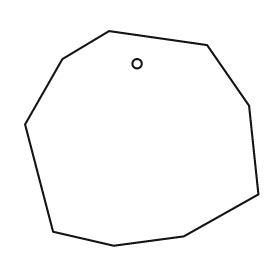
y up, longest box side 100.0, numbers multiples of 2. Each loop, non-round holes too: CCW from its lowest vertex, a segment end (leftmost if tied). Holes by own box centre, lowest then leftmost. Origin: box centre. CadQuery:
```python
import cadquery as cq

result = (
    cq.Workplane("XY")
    .moveTo(-12.0, -46.0)
    .lineTo(18.0, -42.0)
    .lineTo(50.0, -24.0)
    .lineTo(46.0, 14.0)
    .lineTo(28.0, 40.0)
    .lineTo(-14.0, 46.0)
    .lineTo(-34.0, 34.0)
    .lineTo(-50.0, 6.0)
    .lineTo(-38.0, -40.0)
    .close()
    .moveTo(-2.0, 32.0)
    .circle(2.0)
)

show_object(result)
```